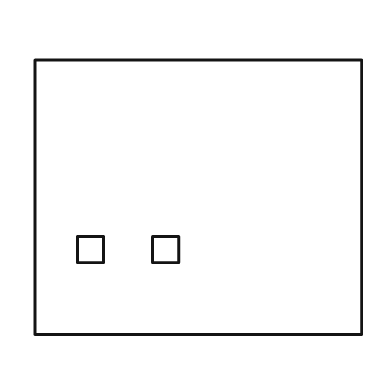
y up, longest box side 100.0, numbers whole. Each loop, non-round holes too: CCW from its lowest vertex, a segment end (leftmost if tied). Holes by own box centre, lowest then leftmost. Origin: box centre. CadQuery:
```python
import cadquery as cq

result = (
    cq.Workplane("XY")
    .moveTo(-50.0, -42.0)
    .lineTo(50.0, -42.0)
    .lineTo(50.0, 42.0)
    .lineTo(-50.0, 42.0)
    .close()
    .moveTo(-37.0, -20.0)
    .lineTo(-29.0, -20.0)
    .lineTo(-29.0, -12.0)
    .lineTo(-37.0, -12.0)
    .close()
    .moveTo(-14.0, -20.0)
    .lineTo(-6.0, -20.0)
    .lineTo(-6.0, -12.0)
    .lineTo(-14.0, -12.0)
    .close()
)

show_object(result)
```